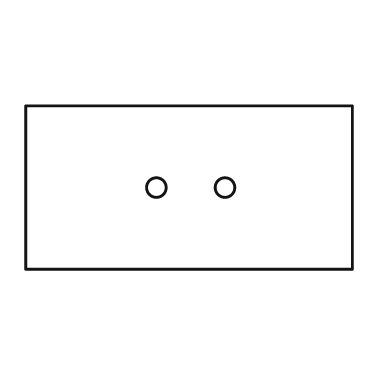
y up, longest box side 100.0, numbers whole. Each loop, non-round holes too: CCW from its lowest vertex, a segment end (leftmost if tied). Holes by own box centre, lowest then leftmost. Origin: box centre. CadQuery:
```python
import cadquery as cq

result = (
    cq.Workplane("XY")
    .moveTo(-50.0, -25.0)
    .lineTo(50.0, -25.0)
    .lineTo(50.0, 25.0)
    .lineTo(-50.0, 25.0)
    .close()
    .moveTo(-10.0, 0.0)
    .circle(3.0)
    .moveTo(11.0, 0.0)
    .circle(3.0)
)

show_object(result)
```